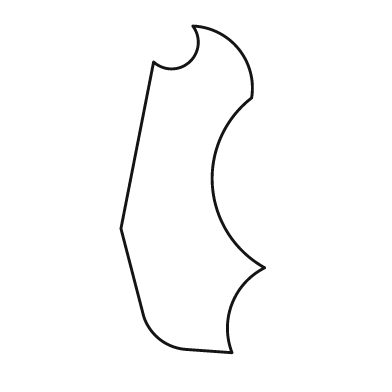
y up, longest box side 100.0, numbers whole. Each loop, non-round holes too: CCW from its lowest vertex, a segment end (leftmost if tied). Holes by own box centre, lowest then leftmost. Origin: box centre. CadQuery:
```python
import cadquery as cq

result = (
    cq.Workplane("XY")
    .moveTo(12.0, -50.0)
    .threePointArc((12.0, -35.0), (22.0, -24.0))
    .threePointArc((6.0, 1.0), (18.0, 28.0))
    .threePointArc((14.0, 43.0), (0.0, 50.0))
    .threePointArc((-1.0, 39.0), (-12.0, 39.0))
    .lineTo(-22.0, -12.0)
    .lineTo(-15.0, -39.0)
    .threePointArc((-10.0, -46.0), (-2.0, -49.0))
    .close()
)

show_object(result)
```